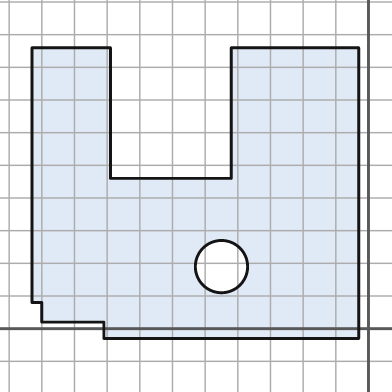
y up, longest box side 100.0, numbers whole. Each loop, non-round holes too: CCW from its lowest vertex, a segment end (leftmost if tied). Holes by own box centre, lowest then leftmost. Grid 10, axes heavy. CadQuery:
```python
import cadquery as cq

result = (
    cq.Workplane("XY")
    .moveTo(-81.0, -3.0)
    .lineTo(-3.0, -3.0)
    .lineTo(-3.0, 86.0)
    .lineTo(-42.0, 86.0)
    .lineTo(-42.0, 46.0)
    .lineTo(-79.0, 46.0)
    .lineTo(-79.0, 86.0)
    .lineTo(-103.0, 86.0)
    .lineTo(-103.0, 8.0)
    .lineTo(-100.0, 8.0)
    .lineTo(-100.0, 2.0)
    .lineTo(-81.0, 2.0)
    .close()
    .moveTo(-45.0, 19.0)
    .circle(8.0)
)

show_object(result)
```